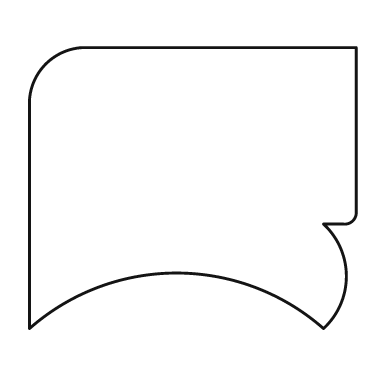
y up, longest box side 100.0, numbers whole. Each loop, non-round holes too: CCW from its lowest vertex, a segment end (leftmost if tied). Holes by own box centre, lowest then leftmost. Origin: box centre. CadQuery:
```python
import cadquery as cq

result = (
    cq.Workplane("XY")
    .moveTo(-50.0, -43.0)
    .threePointArc((-5.0, -26.0), (40.0, -43.0))
    .threePointArc((47.0, -27.0), (40.0, -11.0))
    .lineTo(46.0, -11.0)
    .threePointArc((49.0, -10.0), (50.0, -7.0))
    .lineTo(50.0, 43.0)
    .lineTo(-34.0, 43.0)
    .threePointArc((-45.0, 38.0), (-50.0, 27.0))
    .close()
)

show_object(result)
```